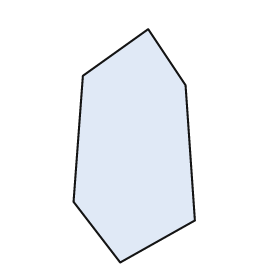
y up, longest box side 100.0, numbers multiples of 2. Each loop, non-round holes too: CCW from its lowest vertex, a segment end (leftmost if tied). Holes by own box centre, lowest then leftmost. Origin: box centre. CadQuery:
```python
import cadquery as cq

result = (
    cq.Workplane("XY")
    .moveTo(-6.0, -50.0)
    .lineTo(26.0, -32.0)
    .lineTo(22.0, 26.0)
    .lineTo(6.0, 50.0)
    .lineTo(-22.0, 30.0)
    .lineTo(-26.0, -24.0)
    .close()
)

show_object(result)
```